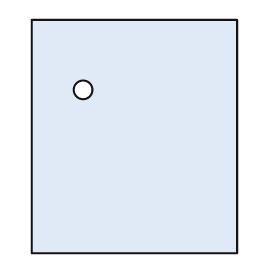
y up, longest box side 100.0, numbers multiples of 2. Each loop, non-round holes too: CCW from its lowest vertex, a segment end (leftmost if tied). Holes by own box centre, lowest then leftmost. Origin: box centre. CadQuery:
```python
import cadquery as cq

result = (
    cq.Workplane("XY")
    .moveTo(-44.0, -50.0)
    .lineTo(44.0, -50.0)
    .lineTo(44.0, 50.0)
    .lineTo(-44.0, 50.0)
    .close()
    .moveTo(-22.0, 20.0)
    .circle(4.0)
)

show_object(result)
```